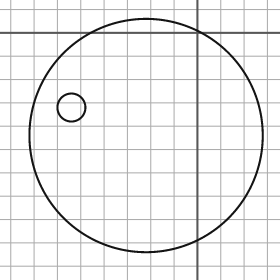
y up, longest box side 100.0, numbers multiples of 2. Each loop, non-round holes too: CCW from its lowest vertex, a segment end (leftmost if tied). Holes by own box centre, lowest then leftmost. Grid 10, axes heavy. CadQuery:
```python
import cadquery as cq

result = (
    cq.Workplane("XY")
    .moveTo(-22.0, -44.0)
    .circle(50.0)
    .moveTo(-54.0, -32.0)
    .circle(6.0)
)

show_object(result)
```